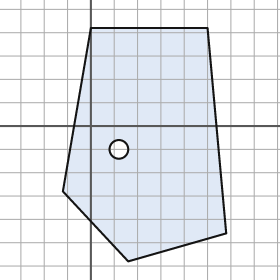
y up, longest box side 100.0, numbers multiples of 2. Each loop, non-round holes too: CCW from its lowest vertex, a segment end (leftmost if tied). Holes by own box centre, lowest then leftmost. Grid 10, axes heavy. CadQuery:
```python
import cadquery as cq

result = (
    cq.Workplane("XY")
    .moveTo(16.0, -58.0)
    .lineTo(58.0, -46.0)
    .lineTo(50.0, 42.0)
    .lineTo(0.0, 42.0)
    .lineTo(-12.0, -28.0)
    .close()
    .moveTo(12.0, -10.0)
    .circle(4.0)
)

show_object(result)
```